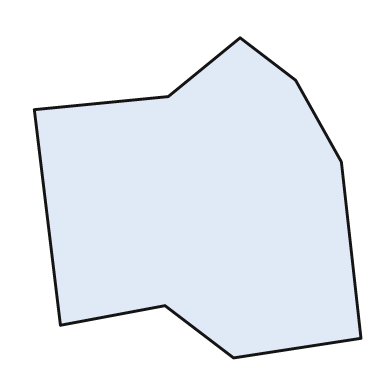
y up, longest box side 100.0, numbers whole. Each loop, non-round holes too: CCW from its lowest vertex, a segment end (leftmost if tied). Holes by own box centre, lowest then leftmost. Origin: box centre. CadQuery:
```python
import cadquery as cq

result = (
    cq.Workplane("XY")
    .moveTo(11.0, -49.0)
    .lineTo(50.0, -43.0)
    .lineTo(44.0, 11.0)
    .lineTo(30.0, 36.0)
    .lineTo(13.0, 49.0)
    .lineTo(-9.0, 31.0)
    .lineTo(-50.0, 27.0)
    .lineTo(-42.0, -39.0)
    .lineTo(-10.0, -33.0)
    .close()
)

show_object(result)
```